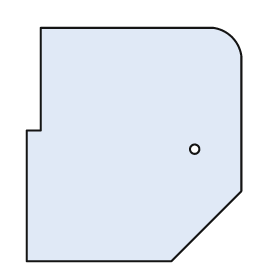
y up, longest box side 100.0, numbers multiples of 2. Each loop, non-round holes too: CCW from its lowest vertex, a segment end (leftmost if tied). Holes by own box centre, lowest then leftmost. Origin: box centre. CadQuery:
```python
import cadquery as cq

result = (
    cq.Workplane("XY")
    .moveTo(-46.0, -50.0)
    .lineTo(16.0, -50.0)
    .lineTo(46.0, -20.0)
    .lineTo(46.0, 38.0)
    .threePointArc((42.0, 46.0), (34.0, 50.0))
    .lineTo(-40.0, 50.0)
    .lineTo(-40.0, 6.0)
    .lineTo(-46.0, 6.0)
    .close()
    .moveTo(26.0, -2.0)
    .circle(2.0)
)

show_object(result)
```